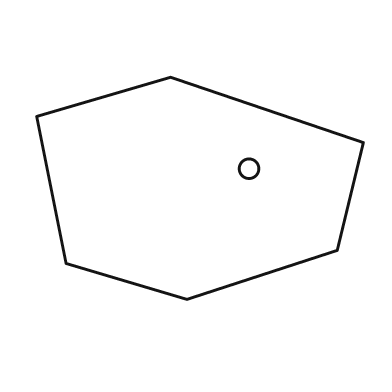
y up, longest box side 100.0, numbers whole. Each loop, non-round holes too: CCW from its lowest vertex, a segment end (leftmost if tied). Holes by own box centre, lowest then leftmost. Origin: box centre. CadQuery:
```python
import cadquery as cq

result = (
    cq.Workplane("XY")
    .moveTo(-4.0, -34.0)
    .lineTo(42.0, -19.0)
    .lineTo(50.0, 14.0)
    .lineTo(-9.0, 34.0)
    .lineTo(-50.0, 22.0)
    .lineTo(-41.0, -23.0)
    .close()
    .moveTo(15.0, 6.0)
    .circle(3.0)
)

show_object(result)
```